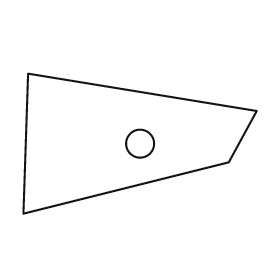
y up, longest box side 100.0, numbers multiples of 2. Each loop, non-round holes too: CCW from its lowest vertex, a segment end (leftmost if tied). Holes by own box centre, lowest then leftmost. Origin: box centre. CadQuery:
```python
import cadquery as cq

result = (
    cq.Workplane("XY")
    .moveTo(-50.0, -30.0)
    .lineTo(38.0, -8.0)
    .lineTo(50.0, 14.0)
    .lineTo(-48.0, 30.0)
    .close()
    .moveTo(0.0, 0.0)
    .circle(6.0)
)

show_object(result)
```